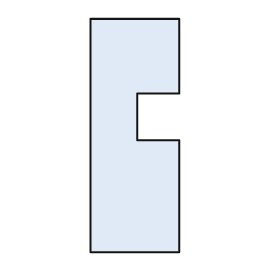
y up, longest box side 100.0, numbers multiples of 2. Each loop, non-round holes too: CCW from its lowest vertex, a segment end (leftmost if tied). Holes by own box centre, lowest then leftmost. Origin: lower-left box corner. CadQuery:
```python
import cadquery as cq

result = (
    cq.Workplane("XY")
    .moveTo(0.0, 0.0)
    .lineTo(38.0, 0.0)
    .lineTo(38.0, 48.0)
    .lineTo(20.0, 48.0)
    .lineTo(20.0, 68.0)
    .lineTo(38.0, 68.0)
    .lineTo(38.0, 100.0)
    .lineTo(0.0, 100.0)
    .close()
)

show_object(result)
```